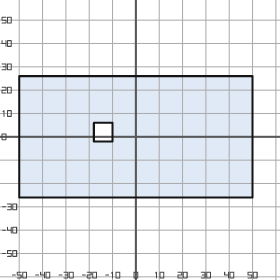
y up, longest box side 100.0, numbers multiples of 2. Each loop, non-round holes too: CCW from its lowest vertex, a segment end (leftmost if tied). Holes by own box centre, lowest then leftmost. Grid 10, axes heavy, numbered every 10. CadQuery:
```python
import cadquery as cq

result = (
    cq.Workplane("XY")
    .moveTo(-50.0, -26.0)
    .lineTo(50.0, -26.0)
    .lineTo(50.0, 26.0)
    .lineTo(-50.0, 26.0)
    .close()
    .moveTo(-18.0, -2.0)
    .lineTo(-10.0, -2.0)
    .lineTo(-10.0, 6.0)
    .lineTo(-18.0, 6.0)
    .close()
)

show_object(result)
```